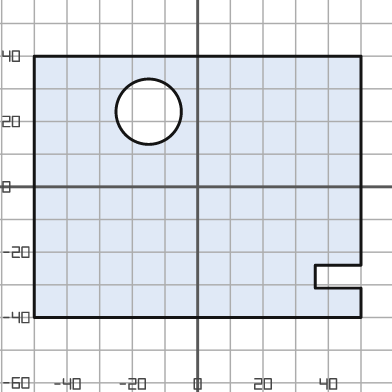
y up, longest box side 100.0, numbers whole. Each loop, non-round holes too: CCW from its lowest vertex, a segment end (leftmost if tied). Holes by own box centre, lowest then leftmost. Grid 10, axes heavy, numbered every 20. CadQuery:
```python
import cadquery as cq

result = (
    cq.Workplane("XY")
    .moveTo(-50.0, -40.0)
    .lineTo(50.0, -40.0)
    .lineTo(50.0, -31.0)
    .lineTo(36.0, -31.0)
    .lineTo(36.0, -24.0)
    .lineTo(50.0, -24.0)
    .lineTo(50.0, 40.0)
    .lineTo(-50.0, 40.0)
    .close()
    .moveTo(-15.0, 23.0)
    .circle(10.0)
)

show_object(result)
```